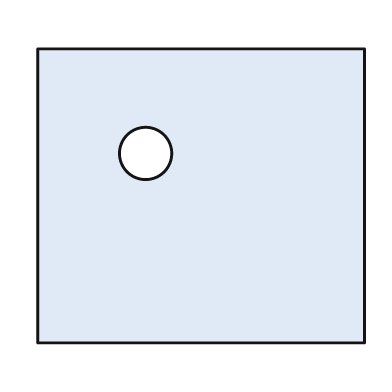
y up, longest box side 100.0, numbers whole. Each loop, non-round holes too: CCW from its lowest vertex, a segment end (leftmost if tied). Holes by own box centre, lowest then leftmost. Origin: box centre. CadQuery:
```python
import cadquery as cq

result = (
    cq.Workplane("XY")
    .moveTo(-50.0, -45.0)
    .lineTo(50.0, -45.0)
    .lineTo(50.0, 45.0)
    .lineTo(-50.0, 45.0)
    .close()
    .moveTo(-17.0, 13.0)
    .circle(8.0)
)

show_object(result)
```